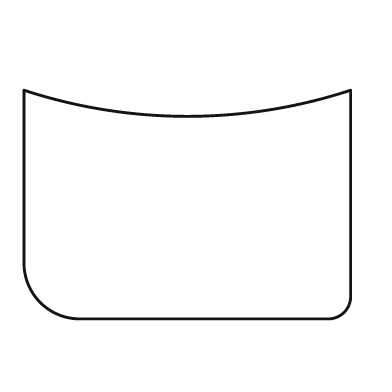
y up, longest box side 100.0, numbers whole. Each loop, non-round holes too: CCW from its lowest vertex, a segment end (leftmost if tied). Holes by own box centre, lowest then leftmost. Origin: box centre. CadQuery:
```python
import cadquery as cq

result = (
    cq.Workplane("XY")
    .moveTo(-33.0, -35.0)
    .lineTo(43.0, -35.0)
    .threePointArc((48.0, -33.0), (50.0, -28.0))
    .lineTo(50.0, 35.0)
    .threePointArc((0.0, 27.0), (-50.0, 35.0))
    .lineTo(-50.0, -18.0)
    .threePointArc((-45.0, -30.0), (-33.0, -35.0))
    .close()
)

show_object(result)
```